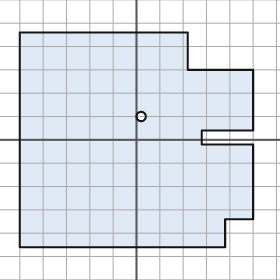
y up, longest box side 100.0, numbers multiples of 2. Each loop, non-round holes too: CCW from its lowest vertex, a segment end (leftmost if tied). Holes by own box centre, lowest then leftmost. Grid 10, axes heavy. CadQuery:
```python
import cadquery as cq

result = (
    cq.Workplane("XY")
    .moveTo(-50.0, -46.0)
    .lineTo(38.0, -46.0)
    .lineTo(38.0, -34.0)
    .lineTo(50.0, -34.0)
    .lineTo(50.0, -2.0)
    .lineTo(28.0, -2.0)
    .lineTo(28.0, 4.0)
    .lineTo(50.0, 4.0)
    .lineTo(50.0, 30.0)
    .lineTo(22.0, 30.0)
    .lineTo(22.0, 46.0)
    .lineTo(-50.0, 46.0)
    .close()
    .moveTo(2.0, 10.0)
    .circle(2.0)
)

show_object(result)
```